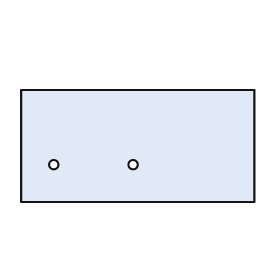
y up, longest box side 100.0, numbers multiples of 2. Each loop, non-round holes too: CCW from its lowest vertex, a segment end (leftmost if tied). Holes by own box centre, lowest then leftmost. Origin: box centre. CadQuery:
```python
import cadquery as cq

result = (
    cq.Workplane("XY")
    .moveTo(-50.0, -24.0)
    .lineTo(50.0, -24.0)
    .lineTo(50.0, 24.0)
    .lineTo(-50.0, 24.0)
    .close()
    .moveTo(-36.0, -8.0)
    .circle(2.0)
    .moveTo(-2.0, -8.0)
    .circle(2.0)
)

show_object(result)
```